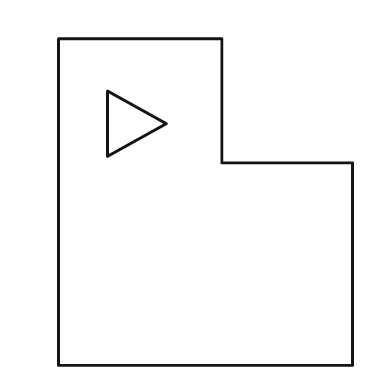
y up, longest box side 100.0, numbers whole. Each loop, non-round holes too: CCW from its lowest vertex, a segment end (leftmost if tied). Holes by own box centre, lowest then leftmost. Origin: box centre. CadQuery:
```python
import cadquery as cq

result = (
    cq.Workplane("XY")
    .moveTo(-45.0, -50.0)
    .lineTo(45.0, -50.0)
    .lineTo(45.0, 12.0)
    .lineTo(5.0, 12.0)
    .lineTo(5.0, 50.0)
    .lineTo(-45.0, 50.0)
    .close()
    .moveTo(-30.0, 14.0)
    .lineTo(-12.0, 24.0)
    .lineTo(-30.0, 34.0)
    .close()
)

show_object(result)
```